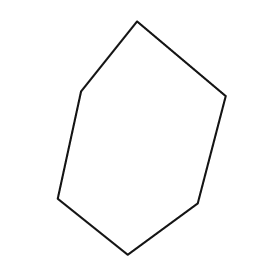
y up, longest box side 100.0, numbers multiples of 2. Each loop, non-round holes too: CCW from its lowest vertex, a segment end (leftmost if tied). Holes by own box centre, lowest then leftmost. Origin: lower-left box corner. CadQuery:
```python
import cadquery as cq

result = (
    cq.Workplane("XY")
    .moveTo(30.0, 0.0)
    .lineTo(60.0, 22.0)
    .lineTo(72.0, 68.0)
    .lineTo(34.0, 100.0)
    .lineTo(10.0, 70.0)
    .lineTo(0.0, 24.0)
    .close()
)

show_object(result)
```